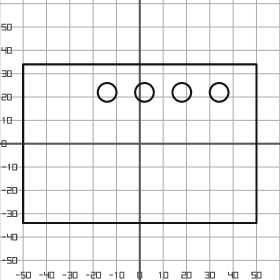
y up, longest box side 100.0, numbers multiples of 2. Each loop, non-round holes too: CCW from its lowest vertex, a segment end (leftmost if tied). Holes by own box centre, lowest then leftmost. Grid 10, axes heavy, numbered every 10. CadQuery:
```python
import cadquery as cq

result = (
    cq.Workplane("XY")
    .moveTo(-50.0, -34.0)
    .lineTo(50.0, -34.0)
    .lineTo(50.0, 34.0)
    .lineTo(-50.0, 34.0)
    .close()
    .moveTo(-14.0, 22.0)
    .circle(4.0)
    .moveTo(2.0, 22.0)
    .circle(4.0)
    .moveTo(18.0, 22.0)
    .circle(4.0)
    .moveTo(34.0, 22.0)
    .circle(4.0)
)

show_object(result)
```